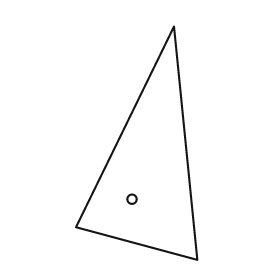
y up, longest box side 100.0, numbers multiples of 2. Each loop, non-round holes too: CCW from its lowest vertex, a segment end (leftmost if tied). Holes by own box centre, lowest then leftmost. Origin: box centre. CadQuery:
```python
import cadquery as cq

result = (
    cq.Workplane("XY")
    .moveTo(26.0, -50.0)
    .lineTo(16.0, 50.0)
    .lineTo(-26.0, -36.0)
    .close()
    .moveTo(-2.0, -24.0)
    .circle(2.0)
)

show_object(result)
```